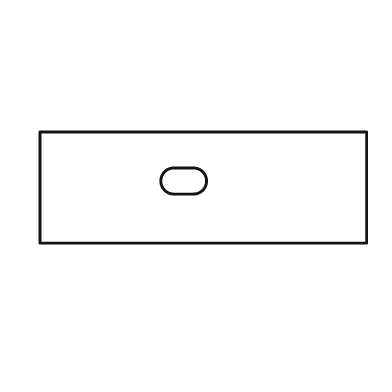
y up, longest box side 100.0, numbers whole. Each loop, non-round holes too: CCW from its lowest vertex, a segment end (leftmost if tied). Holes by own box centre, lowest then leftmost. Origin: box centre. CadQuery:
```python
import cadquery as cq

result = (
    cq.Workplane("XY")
    .moveTo(-50.0, -17.0)
    .lineTo(50.0, -17.0)
    .lineTo(50.0, 17.0)
    .lineTo(-50.0, 17.0)
    .close()
    .moveTo(-9.0, -2.0)
    .lineTo(-3.0, -2.0)
    .threePointArc((1.0, 2.0), (-3.0, 6.0))
    .lineTo(-9.0, 6.0)
    .threePointArc((-13.0, 2.0), (-9.0, -2.0))
    .close()
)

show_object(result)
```